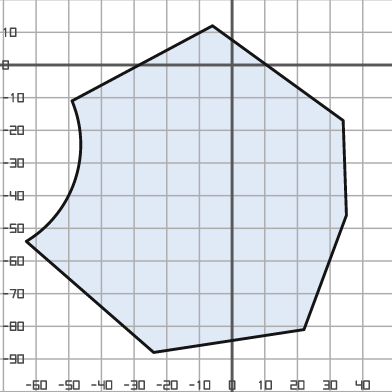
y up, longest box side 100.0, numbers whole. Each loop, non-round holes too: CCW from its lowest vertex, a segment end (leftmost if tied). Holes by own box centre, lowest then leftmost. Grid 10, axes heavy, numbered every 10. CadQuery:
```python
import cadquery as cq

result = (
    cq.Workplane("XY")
    .moveTo(-24.0, -88.0)
    .lineTo(22.0, -81.0)
    .lineTo(35.0, -46.0)
    .lineTo(34.0, -17.0)
    .lineTo(-6.0, 12.0)
    .lineTo(-49.0, -11.0)
    .threePointArc((-48.0, -35.0), (-63.0, -54.0))
    .close()
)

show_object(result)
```